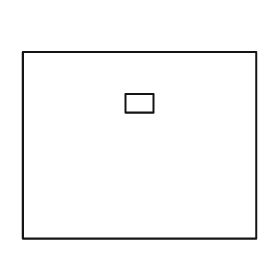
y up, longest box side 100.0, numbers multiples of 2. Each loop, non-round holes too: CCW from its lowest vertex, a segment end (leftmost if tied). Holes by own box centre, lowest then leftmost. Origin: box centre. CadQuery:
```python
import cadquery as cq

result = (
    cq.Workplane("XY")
    .moveTo(-50.0, -40.0)
    .lineTo(50.0, -40.0)
    .lineTo(50.0, 40.0)
    .lineTo(-50.0, 40.0)
    .close()
    .moveTo(-6.0, 14.0)
    .lineTo(6.0, 14.0)
    .lineTo(6.0, 22.0)
    .lineTo(-6.0, 22.0)
    .close()
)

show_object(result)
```